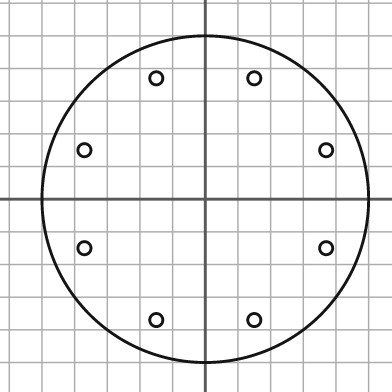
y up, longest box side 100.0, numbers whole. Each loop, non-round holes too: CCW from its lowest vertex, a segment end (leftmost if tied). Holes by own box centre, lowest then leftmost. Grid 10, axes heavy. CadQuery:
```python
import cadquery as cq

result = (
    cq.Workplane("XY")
    .moveTo(0.0, 0.0)
    .circle(50.0)
    .moveTo(-15.0, -37.0)
    .circle(2.0)
    .moveTo(15.0, -37.0)
    .circle(2.0)
    .moveTo(-37.0, -15.0)
    .circle(2.0)
    .moveTo(37.0, -15.0)
    .circle(2.0)
    .moveTo(-37.0, 15.0)
    .circle(2.0)
    .moveTo(37.0, 15.0)
    .circle(2.0)
    .moveTo(-15.0, 37.0)
    .circle(2.0)
    .moveTo(15.0, 37.0)
    .circle(2.0)
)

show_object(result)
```